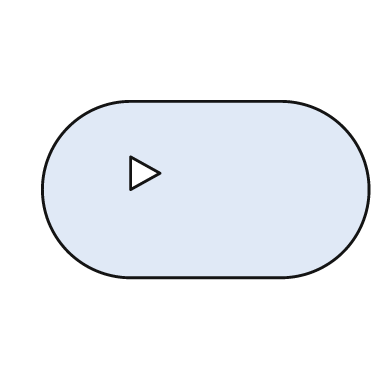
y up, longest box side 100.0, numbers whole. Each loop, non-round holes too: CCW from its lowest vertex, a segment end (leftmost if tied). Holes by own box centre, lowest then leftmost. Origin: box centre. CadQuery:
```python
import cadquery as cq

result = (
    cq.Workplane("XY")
    .moveTo(-23.0, -27.0)
    .lineTo(23.0, -27.0)
    .threePointArc((50.0, 0.0), (23.0, 27.0))
    .lineTo(-23.0, 27.0)
    .threePointArc((-50.0, 0.0), (-23.0, -27.0))
    .close()
    .moveTo(-23.0, 0.0)
    .lineTo(-14.0, 5.0)
    .lineTo(-23.0, 10.0)
    .close()
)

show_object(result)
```